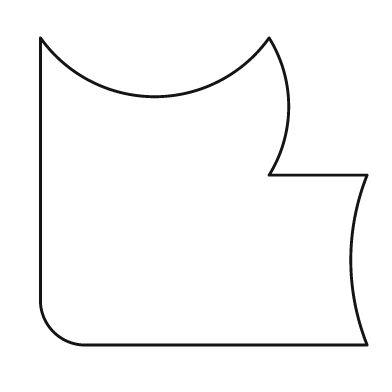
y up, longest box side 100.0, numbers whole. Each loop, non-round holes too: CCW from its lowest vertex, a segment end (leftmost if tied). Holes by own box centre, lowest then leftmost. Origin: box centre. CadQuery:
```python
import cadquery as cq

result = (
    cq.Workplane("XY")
    .moveTo(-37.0, -47.0)
    .lineTo(50.0, -47.0)
    .threePointArc((45.0, -21.0), (50.0, 5.0))
    .lineTo(20.0, 5.0)
    .threePointArc((26.0, 26.0), (20.0, 47.0))
    .threePointArc((-15.0, 29.0), (-50.0, 47.0))
    .lineTo(-50.0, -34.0)
    .threePointArc((-46.0, -43.0), (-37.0, -47.0))
    .close()
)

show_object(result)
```